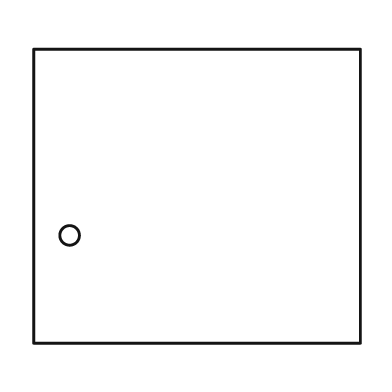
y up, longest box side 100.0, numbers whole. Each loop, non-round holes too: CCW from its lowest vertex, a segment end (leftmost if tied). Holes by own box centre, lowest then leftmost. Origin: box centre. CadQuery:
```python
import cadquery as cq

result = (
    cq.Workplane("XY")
    .moveTo(-50.0, -45.0)
    .lineTo(50.0, -45.0)
    .lineTo(50.0, 45.0)
    .lineTo(-50.0, 45.0)
    .close()
    .moveTo(-39.0, -12.0)
    .circle(3.0)
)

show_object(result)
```